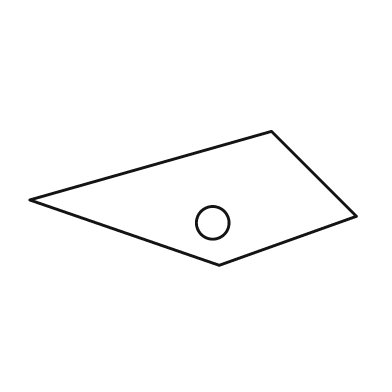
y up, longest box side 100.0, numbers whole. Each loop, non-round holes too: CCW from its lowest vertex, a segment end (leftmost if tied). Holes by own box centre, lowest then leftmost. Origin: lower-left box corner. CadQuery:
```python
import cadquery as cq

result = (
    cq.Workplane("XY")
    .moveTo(58.0, 0.0)
    .lineTo(100.0, 15.0)
    .lineTo(74.0, 41.0)
    .lineTo(0.0, 20.0)
    .close()
    .moveTo(56.0, 13.0)
    .circle(5.0)
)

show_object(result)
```